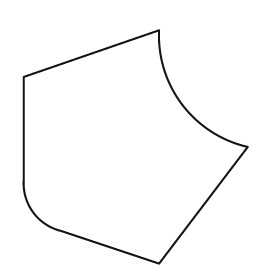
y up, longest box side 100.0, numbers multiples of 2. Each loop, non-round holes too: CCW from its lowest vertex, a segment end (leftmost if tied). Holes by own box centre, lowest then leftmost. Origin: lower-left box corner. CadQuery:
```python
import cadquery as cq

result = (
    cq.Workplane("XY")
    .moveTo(58.0, 0.0)
    .lineTo(96.0, 50.0)
    .threePointArc((68.0, 68.0), (58.0, 100.0))
    .lineTo(0.0, 80.0)
    .lineTo(0.0, 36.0)
    .threePointArc((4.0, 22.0), (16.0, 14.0))
    .close()
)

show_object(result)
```